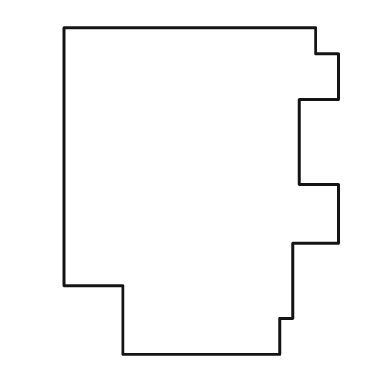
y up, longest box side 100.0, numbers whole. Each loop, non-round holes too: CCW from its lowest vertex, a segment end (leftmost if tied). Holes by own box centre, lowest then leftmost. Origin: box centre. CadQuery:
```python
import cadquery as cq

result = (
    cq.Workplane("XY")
    .moveTo(-24.0, -50.0)
    .lineTo(24.0, -50.0)
    .lineTo(24.0, -39.0)
    .lineTo(28.0, -39.0)
    .lineTo(28.0, -16.0)
    .lineTo(42.0, -16.0)
    .lineTo(42.0, 2.0)
    .lineTo(30.0, 2.0)
    .lineTo(30.0, 28.0)
    .lineTo(42.0, 28.0)
    .lineTo(42.0, 42.0)
    .lineTo(35.0, 42.0)
    .lineTo(35.0, 50.0)
    .lineTo(-42.0, 50.0)
    .lineTo(-42.0, -29.0)
    .lineTo(-24.0, -29.0)
    .close()
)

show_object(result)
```